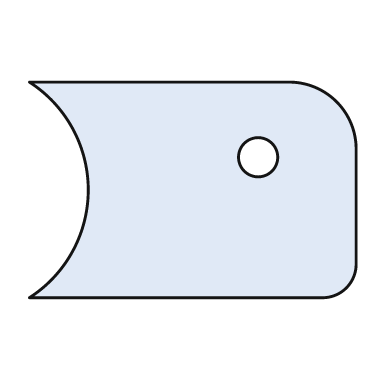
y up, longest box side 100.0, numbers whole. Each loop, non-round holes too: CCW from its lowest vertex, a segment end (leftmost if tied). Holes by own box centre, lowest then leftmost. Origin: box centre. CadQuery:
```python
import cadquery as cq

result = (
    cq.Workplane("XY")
    .moveTo(-50.0, -33.0)
    .lineTo(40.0, -33.0)
    .threePointArc((47.0, -30.0), (50.0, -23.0))
    .lineTo(50.0, 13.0)
    .threePointArc((44.0, 27.0), (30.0, 33.0))
    .lineTo(-50.0, 33.0)
    .threePointArc((-32.0, 0.0), (-50.0, -33.0))
    .close()
    .moveTo(20.0, 10.0)
    .circle(6.0)
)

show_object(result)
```